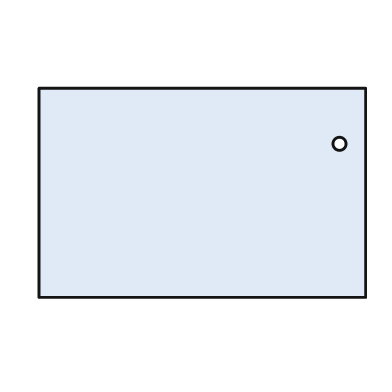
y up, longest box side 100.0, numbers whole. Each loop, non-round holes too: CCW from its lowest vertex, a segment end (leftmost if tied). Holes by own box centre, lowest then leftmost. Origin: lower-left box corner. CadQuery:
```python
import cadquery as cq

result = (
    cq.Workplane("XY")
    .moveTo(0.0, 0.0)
    .lineTo(100.0, 0.0)
    .lineTo(100.0, 64.0)
    .lineTo(0.0, 64.0)
    .close()
    .moveTo(92.0, 47.0)
    .circle(2.0)
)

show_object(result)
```